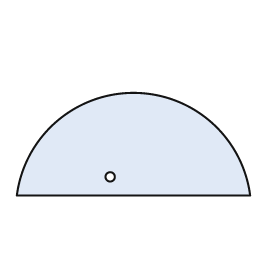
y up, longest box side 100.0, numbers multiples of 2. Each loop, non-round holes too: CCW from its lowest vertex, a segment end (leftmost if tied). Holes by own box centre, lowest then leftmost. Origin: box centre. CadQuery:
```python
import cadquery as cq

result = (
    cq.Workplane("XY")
    .moveTo(-50.0, -22.0)
    .lineTo(50.0, -22.0)
    .threePointArc((0.0, 22.0), (-50.0, -22.0))
    .close()
    .moveTo(-10.0, -14.0)
    .circle(2.0)
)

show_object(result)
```